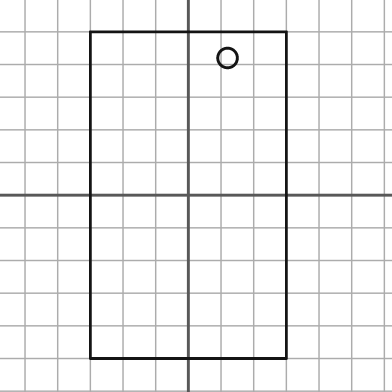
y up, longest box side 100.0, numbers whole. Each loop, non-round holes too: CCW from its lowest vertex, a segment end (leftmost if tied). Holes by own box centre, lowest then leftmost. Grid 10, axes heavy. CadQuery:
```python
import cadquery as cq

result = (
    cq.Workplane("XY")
    .moveTo(-30.0, -50.0)
    .lineTo(30.0, -50.0)
    .lineTo(30.0, 50.0)
    .lineTo(-30.0, 50.0)
    .close()
    .moveTo(12.0, 42.0)
    .circle(3.0)
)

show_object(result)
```